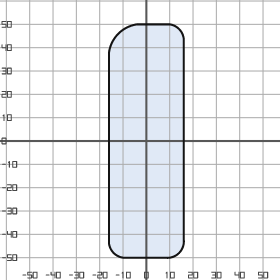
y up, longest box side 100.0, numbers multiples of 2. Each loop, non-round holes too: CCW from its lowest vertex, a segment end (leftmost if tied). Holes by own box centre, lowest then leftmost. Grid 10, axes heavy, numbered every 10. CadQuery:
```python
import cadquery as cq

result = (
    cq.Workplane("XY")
    .moveTo(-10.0, -50.0)
    .lineTo(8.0, -50.0)
    .threePointArc((14.0, -48.0), (16.0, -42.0))
    .lineTo(16.0, 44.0)
    .threePointArc((14.0, 48.0), (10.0, 50.0))
    .lineTo(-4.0, 50.0)
    .threePointArc((-12.0, 46.0), (-16.0, 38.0))
    .lineTo(-16.0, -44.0)
    .threePointArc((-14.0, -48.0), (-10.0, -50.0))
    .close()
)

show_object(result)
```